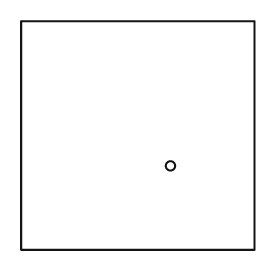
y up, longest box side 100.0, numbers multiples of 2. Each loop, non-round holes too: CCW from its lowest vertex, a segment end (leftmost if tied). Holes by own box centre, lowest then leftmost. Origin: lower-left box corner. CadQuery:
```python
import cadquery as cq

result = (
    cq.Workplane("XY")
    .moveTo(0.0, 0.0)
    .lineTo(100.0, 0.0)
    .lineTo(100.0, 98.0)
    .lineTo(0.0, 98.0)
    .close()
    .moveTo(64.0, 36.0)
    .circle(2.0)
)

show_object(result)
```